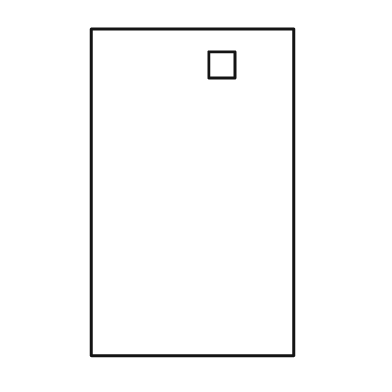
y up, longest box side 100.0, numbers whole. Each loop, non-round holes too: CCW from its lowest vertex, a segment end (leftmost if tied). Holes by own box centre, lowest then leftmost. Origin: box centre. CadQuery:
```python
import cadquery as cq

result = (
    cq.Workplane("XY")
    .moveTo(-31.0, -50.0)
    .lineTo(31.0, -50.0)
    .lineTo(31.0, 50.0)
    .lineTo(-31.0, 50.0)
    .close()
    .moveTo(5.0, 35.0)
    .lineTo(13.0, 35.0)
    .lineTo(13.0, 43.0)
    .lineTo(5.0, 43.0)
    .close()
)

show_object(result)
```